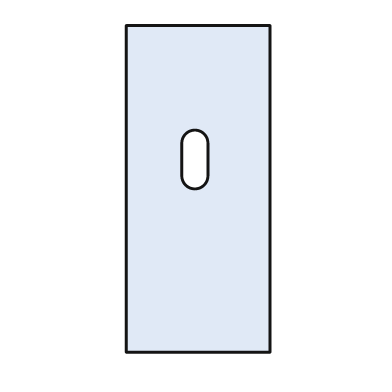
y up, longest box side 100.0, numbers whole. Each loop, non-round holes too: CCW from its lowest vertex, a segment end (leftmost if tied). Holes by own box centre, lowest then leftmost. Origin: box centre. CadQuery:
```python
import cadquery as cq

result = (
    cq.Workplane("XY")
    .moveTo(-22.0, -50.0)
    .lineTo(22.0, -50.0)
    .lineTo(22.0, 50.0)
    .lineTo(-22.0, 50.0)
    .close()
    .moveTo(-5.0, 4.0)
    .threePointArc((-1.0, 0.0), (3.0, 4.0))
    .lineTo(3.0, 14.0)
    .threePointArc((-1.0, 18.0), (-5.0, 14.0))
    .close()
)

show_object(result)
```